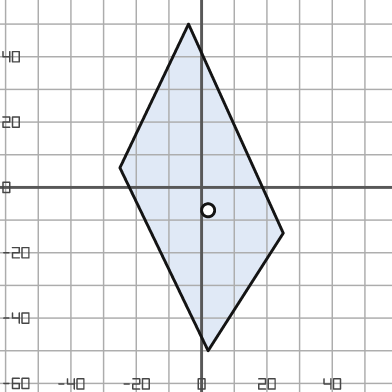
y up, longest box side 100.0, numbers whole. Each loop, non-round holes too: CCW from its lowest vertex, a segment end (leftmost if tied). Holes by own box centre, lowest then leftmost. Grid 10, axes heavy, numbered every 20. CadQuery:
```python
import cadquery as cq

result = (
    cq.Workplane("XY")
    .moveTo(2.0, -50.0)
    .lineTo(25.0, -14.0)
    .lineTo(-4.0, 50.0)
    .lineTo(-25.0, 6.0)
    .close()
    .moveTo(2.0, -7.0)
    .circle(2.0)
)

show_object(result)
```